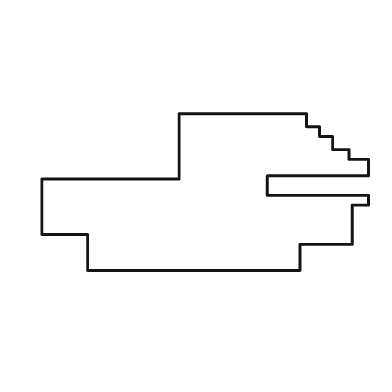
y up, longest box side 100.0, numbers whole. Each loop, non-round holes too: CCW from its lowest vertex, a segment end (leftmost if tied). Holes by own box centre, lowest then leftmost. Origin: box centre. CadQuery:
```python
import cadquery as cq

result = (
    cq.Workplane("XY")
    .moveTo(-36.0, -24.0)
    .lineTo(29.0, -24.0)
    .lineTo(29.0, -16.0)
    .lineTo(45.0, -16.0)
    .lineTo(45.0, -4.0)
    .lineTo(50.0, -4.0)
    .lineTo(50.0, -1.0)
    .lineTo(19.0, -1.0)
    .lineTo(19.0, 5.0)
    .lineTo(50.0, 5.0)
    .lineTo(50.0, 10.0)
    .lineTo(44.0, 10.0)
    .lineTo(44.0, 13.0)
    .lineTo(39.0, 13.0)
    .lineTo(39.0, 17.0)
    .lineTo(35.0, 17.0)
    .lineTo(35.0, 20.0)
    .lineTo(31.0, 20.0)
    .lineTo(31.0, 24.0)
    .lineTo(-8.0, 24.0)
    .lineTo(-8.0, 4.0)
    .lineTo(-50.0, 4.0)
    .lineTo(-50.0, -13.0)
    .lineTo(-36.0, -13.0)
    .close()
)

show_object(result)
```